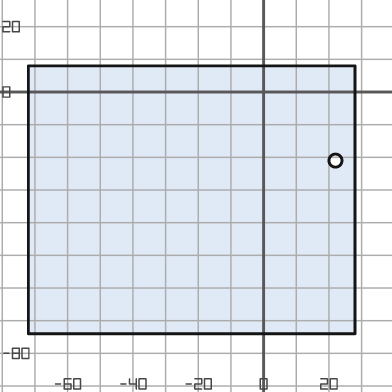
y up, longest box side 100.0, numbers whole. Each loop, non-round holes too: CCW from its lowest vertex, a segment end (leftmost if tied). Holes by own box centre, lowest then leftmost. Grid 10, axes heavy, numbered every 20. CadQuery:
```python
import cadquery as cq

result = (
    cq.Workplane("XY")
    .moveTo(-72.0, -74.0)
    .lineTo(28.0, -74.0)
    .lineTo(28.0, 8.0)
    .lineTo(-72.0, 8.0)
    .close()
    .moveTo(22.0, -21.0)
    .circle(2.0)
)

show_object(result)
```